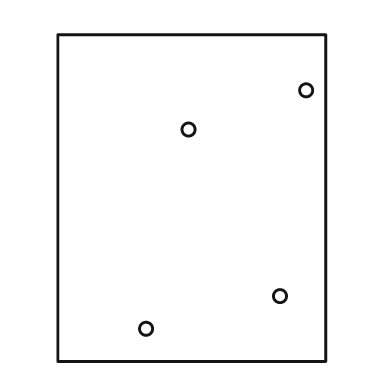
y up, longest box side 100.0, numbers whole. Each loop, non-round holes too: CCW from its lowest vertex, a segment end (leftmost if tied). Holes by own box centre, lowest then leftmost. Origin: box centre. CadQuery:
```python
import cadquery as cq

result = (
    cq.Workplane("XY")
    .moveTo(-41.0, -50.0)
    .lineTo(41.0, -50.0)
    .lineTo(41.0, 50.0)
    .lineTo(-41.0, 50.0)
    .close()
    .moveTo(-14.0, -40.0)
    .circle(2.0)
    .moveTo(27.0, -30.0)
    .circle(2.0)
    .moveTo(-1.0, 21.0)
    .circle(2.0)
    .moveTo(35.0, 33.0)
    .circle(2.0)
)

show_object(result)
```